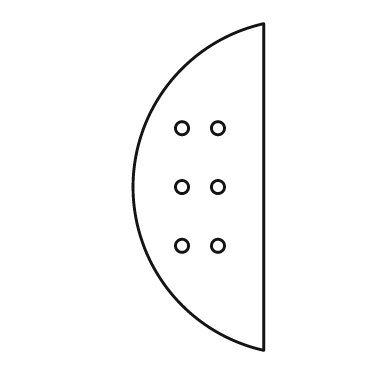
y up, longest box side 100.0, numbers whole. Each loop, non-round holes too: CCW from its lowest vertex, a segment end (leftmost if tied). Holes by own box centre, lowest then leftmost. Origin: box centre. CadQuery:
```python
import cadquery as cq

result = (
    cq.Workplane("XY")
    .moveTo(20.0, -50.0)
    .lineTo(20.0, 50.0)
    .threePointArc((-20.0, 0.0), (20.0, -50.0))
    .close()
    .moveTo(-5.0, -18.0)
    .circle(2.0)
    .moveTo(6.0, -18.0)
    .circle(2.0)
    .moveTo(-5.0, 0.0)
    .circle(2.0)
    .moveTo(6.0, 0.0)
    .circle(2.0)
    .moveTo(-5.0, 18.0)
    .circle(2.0)
    .moveTo(6.0, 18.0)
    .circle(2.0)
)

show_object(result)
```